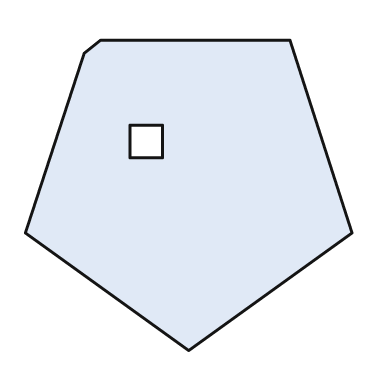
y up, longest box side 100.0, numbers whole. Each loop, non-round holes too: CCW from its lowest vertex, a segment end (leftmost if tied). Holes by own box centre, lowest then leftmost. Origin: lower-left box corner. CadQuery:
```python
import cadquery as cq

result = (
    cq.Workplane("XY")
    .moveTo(50.0, 0.0)
    .lineTo(100.0, 36.0)
    .lineTo(81.0, 95.0)
    .lineTo(23.0, 95.0)
    .lineTo(18.0, 91.0)
    .lineTo(0.0, 36.0)
    .close()
    .moveTo(32.0, 59.0)
    .lineTo(42.0, 59.0)
    .lineTo(42.0, 69.0)
    .lineTo(32.0, 69.0)
    .close()
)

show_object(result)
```